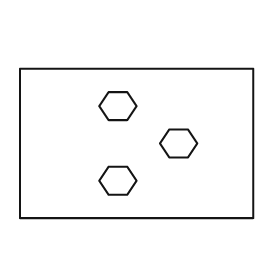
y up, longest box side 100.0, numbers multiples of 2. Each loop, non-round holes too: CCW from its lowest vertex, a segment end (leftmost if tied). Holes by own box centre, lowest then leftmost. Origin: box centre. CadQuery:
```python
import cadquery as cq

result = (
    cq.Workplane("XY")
    .moveTo(-50.0, -32.0)
    .lineTo(50.0, -32.0)
    .lineTo(50.0, 32.0)
    .lineTo(-50.0, 32.0)
    .close()
    .moveTo(-12.0, -22.0)
    .lineTo(-4.0, -22.0)
    .lineTo(0.0, -16.0)
    .lineTo(-4.0, -10.0)
    .lineTo(-12.0, -10.0)
    .lineTo(-16.0, -16.0)
    .close()
    .moveTo(14.0, -6.0)
    .lineTo(22.0, -6.0)
    .lineTo(26.0, 0.0)
    .lineTo(22.0, 6.0)
    .lineTo(14.0, 6.0)
    .lineTo(10.0, 0.0)
    .close()
    .moveTo(-12.0, 10.0)
    .lineTo(-4.0, 10.0)
    .lineTo(0.0, 16.0)
    .lineTo(-4.0, 22.0)
    .lineTo(-12.0, 22.0)
    .lineTo(-16.0, 16.0)
    .close()
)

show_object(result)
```